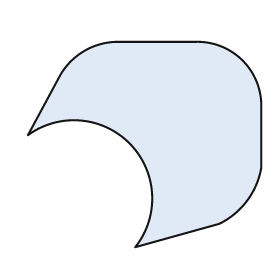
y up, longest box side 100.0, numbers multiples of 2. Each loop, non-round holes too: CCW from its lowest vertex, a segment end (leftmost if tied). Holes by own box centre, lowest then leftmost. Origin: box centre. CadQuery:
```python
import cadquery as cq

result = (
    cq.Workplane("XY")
    .moveTo(-4.0, -44.0)
    .lineTo(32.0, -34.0)
    .threePointArc((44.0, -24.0), (50.0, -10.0))
    .lineTo(50.0, 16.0)
    .threePointArc((42.0, 36.0), (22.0, 44.0))
    .lineTo(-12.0, 44.0)
    .threePointArc((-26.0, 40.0), (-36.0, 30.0))
    .lineTo(-50.0, 4.0)
    .threePointArc((-6.0, 0.0), (-4.0, -44.0))
    .close()
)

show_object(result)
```